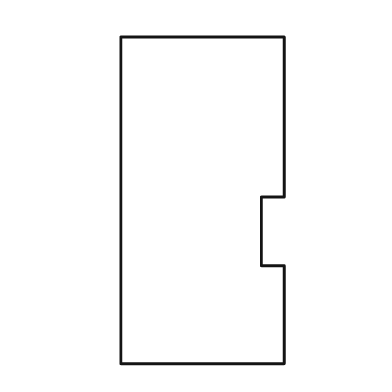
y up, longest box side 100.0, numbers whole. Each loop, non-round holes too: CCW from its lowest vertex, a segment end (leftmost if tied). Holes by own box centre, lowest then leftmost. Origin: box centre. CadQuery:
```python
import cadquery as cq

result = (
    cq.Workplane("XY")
    .moveTo(-25.0, -50.0)
    .lineTo(25.0, -50.0)
    .lineTo(25.0, -20.0)
    .lineTo(18.0, -20.0)
    .lineTo(18.0, 1.0)
    .lineTo(25.0, 1.0)
    .lineTo(25.0, 50.0)
    .lineTo(-25.0, 50.0)
    .close()
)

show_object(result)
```